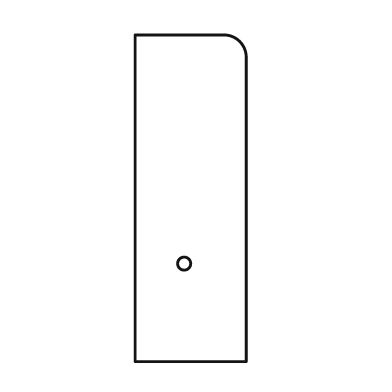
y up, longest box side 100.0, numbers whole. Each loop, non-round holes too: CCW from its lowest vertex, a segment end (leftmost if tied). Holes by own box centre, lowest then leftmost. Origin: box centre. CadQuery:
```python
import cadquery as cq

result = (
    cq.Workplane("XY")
    .moveTo(-17.0, -50.0)
    .lineTo(17.0, -50.0)
    .lineTo(17.0, 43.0)
    .threePointArc((15.0, 48.0), (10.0, 50.0))
    .lineTo(-17.0, 50.0)
    .close()
    .moveTo(-2.0, -20.0)
    .circle(2.0)
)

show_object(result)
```